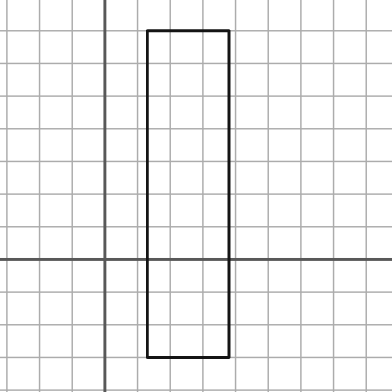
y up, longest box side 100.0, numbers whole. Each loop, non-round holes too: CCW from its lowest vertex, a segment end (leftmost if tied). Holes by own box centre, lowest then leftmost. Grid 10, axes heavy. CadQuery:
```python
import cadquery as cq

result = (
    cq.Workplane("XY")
    .moveTo(13.0, -30.0)
    .lineTo(38.0, -30.0)
    .lineTo(38.0, 70.0)
    .lineTo(13.0, 70.0)
    .close()
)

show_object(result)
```